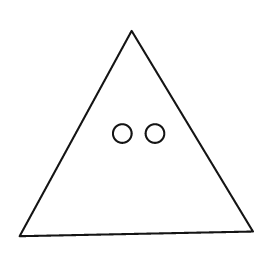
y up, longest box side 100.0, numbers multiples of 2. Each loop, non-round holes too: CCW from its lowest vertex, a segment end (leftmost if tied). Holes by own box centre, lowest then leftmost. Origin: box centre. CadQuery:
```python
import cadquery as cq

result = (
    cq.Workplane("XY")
    .moveTo(-50.0, -44.0)
    .lineTo(50.0, -42.0)
    .lineTo(-2.0, 44.0)
    .close()
    .moveTo(-6.0, 0.0)
    .circle(4.0)
    .moveTo(8.0, 0.0)
    .circle(4.0)
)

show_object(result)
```